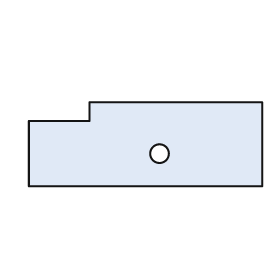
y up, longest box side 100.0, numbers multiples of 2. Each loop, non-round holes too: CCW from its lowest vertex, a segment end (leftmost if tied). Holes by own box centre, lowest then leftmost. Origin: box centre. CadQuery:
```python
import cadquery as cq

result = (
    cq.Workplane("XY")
    .moveTo(-50.0, -18.0)
    .lineTo(50.0, -18.0)
    .lineTo(50.0, 18.0)
    .lineTo(-24.0, 18.0)
    .lineTo(-24.0, 10.0)
    .lineTo(-50.0, 10.0)
    .close()
    .moveTo(6.0, -4.0)
    .circle(4.0)
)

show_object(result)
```